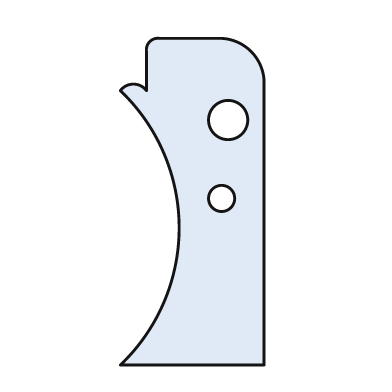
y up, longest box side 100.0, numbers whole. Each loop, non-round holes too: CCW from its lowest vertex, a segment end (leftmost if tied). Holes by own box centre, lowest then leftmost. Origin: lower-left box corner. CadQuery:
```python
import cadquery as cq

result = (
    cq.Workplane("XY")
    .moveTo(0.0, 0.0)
    .lineTo(44.0, 0.0)
    .lineTo(44.0, 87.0)
    .threePointArc((40.0, 96.0), (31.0, 100.0))
    .lineTo(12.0, 100.0)
    .threePointArc((9.0, 99.0), (8.0, 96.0))
    .lineTo(8.0, 84.0)
    .threePointArc((4.0, 86.0), (0.0, 84.0))
    .threePointArc((18.0, 42.0), (0.0, 0.0))
    .close()
    .moveTo(31.0, 51.0)
    .circle(4.0)
    .moveTo(33.0, 75.0)
    .circle(6.0)
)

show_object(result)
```